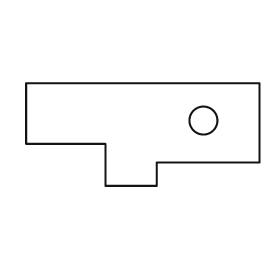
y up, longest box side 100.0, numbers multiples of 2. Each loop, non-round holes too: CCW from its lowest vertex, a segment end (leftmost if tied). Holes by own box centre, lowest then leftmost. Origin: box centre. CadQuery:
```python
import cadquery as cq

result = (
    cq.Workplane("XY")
    .moveTo(-16.0, -22.0)
    .lineTo(6.0, -22.0)
    .lineTo(6.0, -12.0)
    .lineTo(50.0, -12.0)
    .lineTo(50.0, 22.0)
    .lineTo(-50.0, 22.0)
    .lineTo(-50.0, -4.0)
    .lineTo(-16.0, -4.0)
    .close()
    .moveTo(26.0, 6.0)
    .circle(6.0)
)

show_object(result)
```